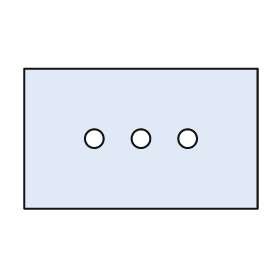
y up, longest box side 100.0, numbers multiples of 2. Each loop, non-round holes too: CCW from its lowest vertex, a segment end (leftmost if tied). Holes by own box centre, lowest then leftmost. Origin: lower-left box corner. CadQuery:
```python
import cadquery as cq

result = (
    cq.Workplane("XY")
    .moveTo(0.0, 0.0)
    .lineTo(100.0, 0.0)
    .lineTo(100.0, 60.0)
    .lineTo(0.0, 60.0)
    .close()
    .moveTo(30.0, 30.0)
    .circle(4.0)
    .moveTo(50.0, 30.0)
    .circle(4.0)
    .moveTo(70.0, 30.0)
    .circle(4.0)
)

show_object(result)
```